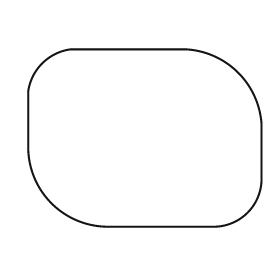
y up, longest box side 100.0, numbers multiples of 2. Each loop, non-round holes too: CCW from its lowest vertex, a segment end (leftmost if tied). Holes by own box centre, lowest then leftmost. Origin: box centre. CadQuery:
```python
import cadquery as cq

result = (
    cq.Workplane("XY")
    .moveTo(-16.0, -38.0)
    .lineTo(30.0, -38.0)
    .threePointArc((44.0, -32.0), (50.0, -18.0))
    .lineTo(50.0, 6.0)
    .threePointArc((40.0, 28.0), (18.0, 38.0))
    .lineTo(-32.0, 38.0)
    .threePointArc((-44.0, 32.0), (-50.0, 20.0))
    .lineTo(-50.0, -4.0)
    .threePointArc((-40.0, -28.0), (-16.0, -38.0))
    .close()
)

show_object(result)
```